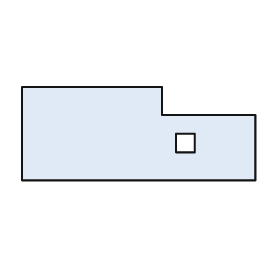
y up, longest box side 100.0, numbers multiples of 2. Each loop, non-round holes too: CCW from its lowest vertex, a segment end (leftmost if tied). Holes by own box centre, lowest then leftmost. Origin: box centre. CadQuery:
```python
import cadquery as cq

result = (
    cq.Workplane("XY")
    .moveTo(-50.0, -20.0)
    .lineTo(50.0, -20.0)
    .lineTo(50.0, 8.0)
    .lineTo(10.0, 8.0)
    .lineTo(10.0, 20.0)
    .lineTo(-50.0, 20.0)
    .close()
    .moveTo(16.0, -8.0)
    .lineTo(24.0, -8.0)
    .lineTo(24.0, 0.0)
    .lineTo(16.0, 0.0)
    .close()
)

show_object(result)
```